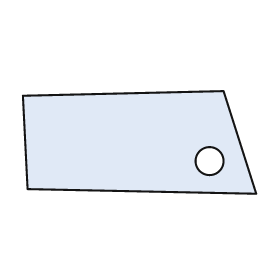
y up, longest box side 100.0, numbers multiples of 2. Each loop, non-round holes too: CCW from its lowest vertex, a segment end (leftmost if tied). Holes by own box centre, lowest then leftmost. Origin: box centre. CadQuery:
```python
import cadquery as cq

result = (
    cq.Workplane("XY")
    .moveTo(50.0, -22.0)
    .lineTo(36.0, 22.0)
    .lineTo(-50.0, 20.0)
    .lineTo(-48.0, -20.0)
    .close()
    .moveTo(30.0, -8.0)
    .circle(6.0)
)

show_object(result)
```